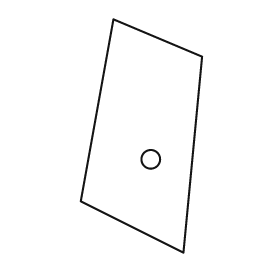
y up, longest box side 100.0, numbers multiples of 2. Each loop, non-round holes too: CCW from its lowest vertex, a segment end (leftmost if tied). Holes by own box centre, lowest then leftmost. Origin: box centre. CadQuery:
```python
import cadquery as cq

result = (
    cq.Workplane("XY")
    .moveTo(18.0, -50.0)
    .lineTo(26.0, 34.0)
    .lineTo(-12.0, 50.0)
    .lineTo(-26.0, -28.0)
    .close()
    .moveTo(4.0, -10.0)
    .circle(4.0)
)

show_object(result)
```